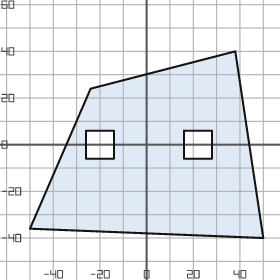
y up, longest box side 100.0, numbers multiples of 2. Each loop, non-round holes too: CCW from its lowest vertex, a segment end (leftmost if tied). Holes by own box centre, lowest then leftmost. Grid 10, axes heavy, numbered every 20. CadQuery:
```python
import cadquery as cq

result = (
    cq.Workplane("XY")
    .moveTo(50.0, -40.0)
    .lineTo(38.0, 40.0)
    .lineTo(-24.0, 24.0)
    .lineTo(-50.0, -36.0)
    .close()
    .moveTo(-26.0, -6.0)
    .lineTo(-14.0, -6.0)
    .lineTo(-14.0, 6.0)
    .lineTo(-26.0, 6.0)
    .close()
    .moveTo(16.0, -6.0)
    .lineTo(28.0, -6.0)
    .lineTo(28.0, 6.0)
    .lineTo(16.0, 6.0)
    .close()
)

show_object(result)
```